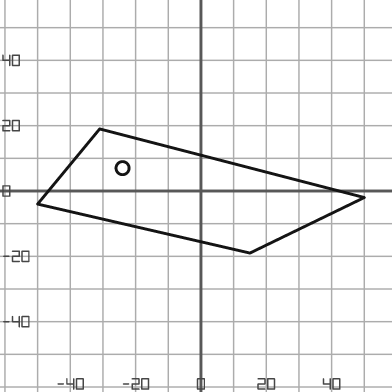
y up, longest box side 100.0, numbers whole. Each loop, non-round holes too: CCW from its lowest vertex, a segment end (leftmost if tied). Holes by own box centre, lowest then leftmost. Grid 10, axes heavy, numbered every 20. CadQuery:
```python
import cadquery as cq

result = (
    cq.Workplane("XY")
    .moveTo(15.0, -19.0)
    .lineTo(50.0, -2.0)
    .lineTo(-31.0, 19.0)
    .lineTo(-50.0, -4.0)
    .close()
    .moveTo(-24.0, 7.0)
    .circle(2.0)
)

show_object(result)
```